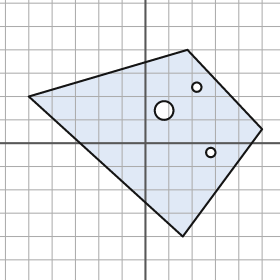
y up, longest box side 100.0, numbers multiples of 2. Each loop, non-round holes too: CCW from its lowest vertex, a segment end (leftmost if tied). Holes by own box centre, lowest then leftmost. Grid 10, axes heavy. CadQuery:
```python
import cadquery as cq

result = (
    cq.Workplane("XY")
    .moveTo(16.0, -40.0)
    .lineTo(50.0, 6.0)
    .lineTo(18.0, 40.0)
    .lineTo(-50.0, 20.0)
    .close()
    .moveTo(28.0, -4.0)
    .circle(2.0)
    .moveTo(8.0, 14.0)
    .circle(4.0)
    .moveTo(22.0, 24.0)
    .circle(2.0)
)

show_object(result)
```